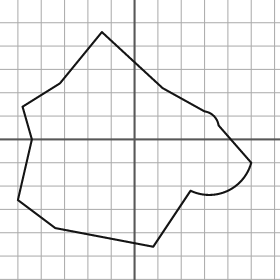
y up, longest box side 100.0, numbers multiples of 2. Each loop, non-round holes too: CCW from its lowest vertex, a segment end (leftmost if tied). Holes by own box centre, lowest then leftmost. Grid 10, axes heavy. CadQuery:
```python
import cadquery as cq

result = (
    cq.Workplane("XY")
    .moveTo(8.0, -46.0)
    .lineTo(24.0, -22.0)
    .threePointArc((40.0, -22.0), (50.0, -10.0))
    .lineTo(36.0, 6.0)
    .threePointArc((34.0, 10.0), (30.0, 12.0))
    .lineTo(12.0, 22.0)
    .lineTo(-14.0, 46.0)
    .lineTo(-32.0, 24.0)
    .lineTo(-48.0, 14.0)
    .lineTo(-44.0, 0.0)
    .lineTo(-50.0, -26.0)
    .lineTo(-34.0, -38.0)
    .close()
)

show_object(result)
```